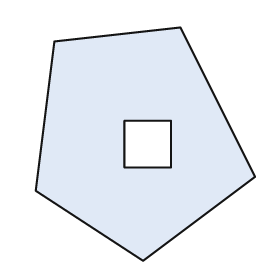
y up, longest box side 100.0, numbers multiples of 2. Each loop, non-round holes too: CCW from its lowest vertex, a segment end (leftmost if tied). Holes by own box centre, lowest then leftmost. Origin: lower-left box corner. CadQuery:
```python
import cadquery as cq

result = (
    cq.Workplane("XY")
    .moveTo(46.0, 0.0)
    .lineTo(94.0, 36.0)
    .lineTo(62.0, 100.0)
    .lineTo(8.0, 94.0)
    .lineTo(0.0, 30.0)
    .close()
    .moveTo(38.0, 40.0)
    .lineTo(58.0, 40.0)
    .lineTo(58.0, 60.0)
    .lineTo(38.0, 60.0)
    .close()
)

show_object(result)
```